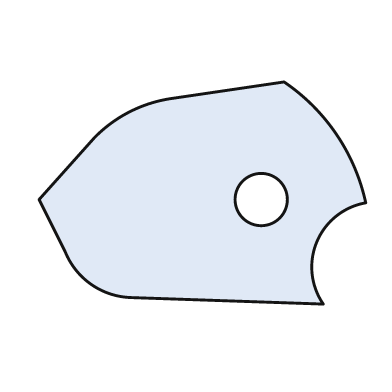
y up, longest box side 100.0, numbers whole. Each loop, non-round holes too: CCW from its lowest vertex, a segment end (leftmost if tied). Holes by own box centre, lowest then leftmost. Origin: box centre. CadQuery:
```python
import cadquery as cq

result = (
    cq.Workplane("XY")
    .moveTo(37.0, -34.0)
    .threePointArc((35.0, -15.0), (50.0, -3.0))
    .threePointArc((41.0, 18.0), (25.0, 34.0))
    .lineTo(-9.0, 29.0)
    .threePointArc((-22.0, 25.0), (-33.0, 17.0))
    .lineTo(-50.0, -2.0)
    .lineTo(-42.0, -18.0)
    .threePointArc((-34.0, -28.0), (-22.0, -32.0))
    .close()
    .moveTo(18.0, -2.0)
    .circle(8.0)
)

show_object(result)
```